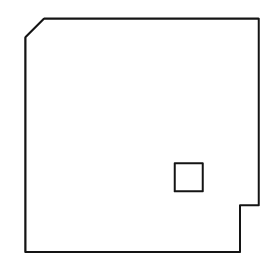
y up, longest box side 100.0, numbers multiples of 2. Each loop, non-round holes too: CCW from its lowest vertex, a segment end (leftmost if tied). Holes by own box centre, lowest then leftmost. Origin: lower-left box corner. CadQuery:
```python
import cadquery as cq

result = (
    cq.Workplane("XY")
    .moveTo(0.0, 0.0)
    .lineTo(92.0, 0.0)
    .lineTo(92.0, 20.0)
    .lineTo(100.0, 20.0)
    .lineTo(100.0, 100.0)
    .lineTo(8.0, 100.0)
    .lineTo(0.0, 92.0)
    .close()
    .moveTo(64.0, 26.0)
    .lineTo(76.0, 26.0)
    .lineTo(76.0, 38.0)
    .lineTo(64.0, 38.0)
    .close()
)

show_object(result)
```